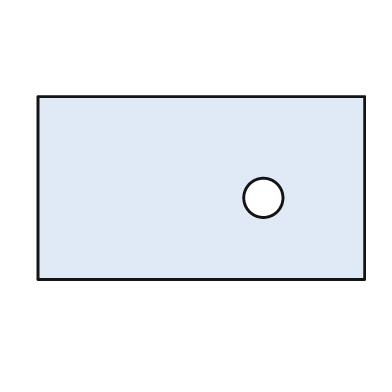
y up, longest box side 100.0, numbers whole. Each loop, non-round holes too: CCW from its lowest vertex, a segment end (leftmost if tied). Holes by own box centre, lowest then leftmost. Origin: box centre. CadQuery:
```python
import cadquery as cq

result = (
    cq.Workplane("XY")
    .moveTo(-50.0, -28.0)
    .lineTo(50.0, -28.0)
    .lineTo(50.0, 28.0)
    .lineTo(-50.0, 28.0)
    .close()
    .moveTo(19.0, -3.0)
    .circle(6.0)
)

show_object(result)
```